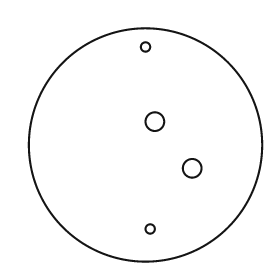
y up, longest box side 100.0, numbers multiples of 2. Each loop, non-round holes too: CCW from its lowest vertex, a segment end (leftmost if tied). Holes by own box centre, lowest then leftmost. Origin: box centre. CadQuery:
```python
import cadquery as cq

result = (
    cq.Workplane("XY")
    .moveTo(0.0, 0.0)
    .circle(50.0)
    .moveTo(2.0, -36.0)
    .circle(2.0)
    .moveTo(20.0, -10.0)
    .circle(4.0)
    .moveTo(4.0, 10.0)
    .circle(4.0)
    .moveTo(0.0, 42.0)
    .circle(2.0)
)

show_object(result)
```